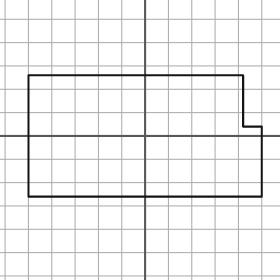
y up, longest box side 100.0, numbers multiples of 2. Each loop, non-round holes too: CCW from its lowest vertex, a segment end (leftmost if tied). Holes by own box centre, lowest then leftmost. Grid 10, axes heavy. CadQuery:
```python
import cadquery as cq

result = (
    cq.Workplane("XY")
    .moveTo(-50.0, -26.0)
    .lineTo(50.0, -26.0)
    .lineTo(50.0, 4.0)
    .lineTo(42.0, 4.0)
    .lineTo(42.0, 26.0)
    .lineTo(-50.0, 26.0)
    .close()
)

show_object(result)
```